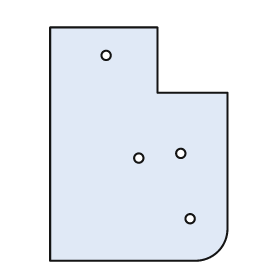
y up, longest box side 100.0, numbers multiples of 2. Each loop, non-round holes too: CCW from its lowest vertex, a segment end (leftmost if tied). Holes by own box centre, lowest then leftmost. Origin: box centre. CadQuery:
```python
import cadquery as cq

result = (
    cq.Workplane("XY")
    .moveTo(-38.0, -50.0)
    .lineTo(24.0, -50.0)
    .threePointArc((34.0, -46.0), (38.0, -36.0))
    .lineTo(38.0, 22.0)
    .lineTo(8.0, 22.0)
    .lineTo(8.0, 50.0)
    .lineTo(-38.0, 50.0)
    .close()
    .moveTo(22.0, -32.0)
    .circle(2.0)
    .moveTo(0.0, -6.0)
    .circle(2.0)
    .moveTo(18.0, -4.0)
    .circle(2.0)
    .moveTo(-14.0, 38.0)
    .circle(2.0)
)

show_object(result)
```